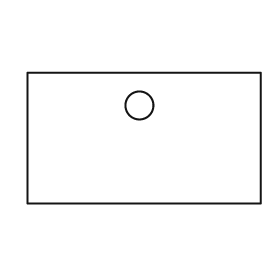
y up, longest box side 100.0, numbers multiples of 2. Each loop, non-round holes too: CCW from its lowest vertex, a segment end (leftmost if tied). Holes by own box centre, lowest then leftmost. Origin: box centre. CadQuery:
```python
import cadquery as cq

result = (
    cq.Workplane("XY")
    .moveTo(-50.0, -28.0)
    .lineTo(50.0, -28.0)
    .lineTo(50.0, 28.0)
    .lineTo(-50.0, 28.0)
    .close()
    .moveTo(-2.0, 14.0)
    .circle(6.0)
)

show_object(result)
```